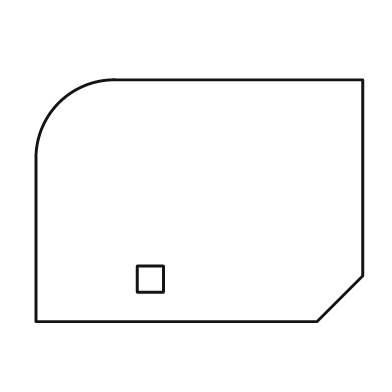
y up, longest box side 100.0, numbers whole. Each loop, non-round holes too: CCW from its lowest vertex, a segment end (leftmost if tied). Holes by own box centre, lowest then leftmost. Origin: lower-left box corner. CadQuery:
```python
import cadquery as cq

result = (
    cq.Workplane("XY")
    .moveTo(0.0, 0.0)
    .lineTo(86.0, 0.0)
    .lineTo(100.0, 14.0)
    .lineTo(100.0, 74.0)
    .lineTo(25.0, 74.0)
    .threePointArc((7.0, 67.0), (0.0, 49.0))
    .close()
    .moveTo(31.0, 9.0)
    .lineTo(39.0, 9.0)
    .lineTo(39.0, 17.0)
    .lineTo(31.0, 17.0)
    .close()
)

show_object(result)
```